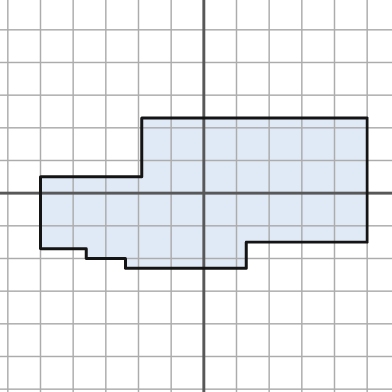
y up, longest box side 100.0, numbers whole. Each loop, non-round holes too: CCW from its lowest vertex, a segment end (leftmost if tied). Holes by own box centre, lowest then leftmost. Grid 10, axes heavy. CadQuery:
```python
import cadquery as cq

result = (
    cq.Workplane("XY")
    .moveTo(-24.0, -23.0)
    .lineTo(13.0, -23.0)
    .lineTo(13.0, -15.0)
    .lineTo(50.0, -15.0)
    .lineTo(50.0, 23.0)
    .lineTo(-19.0, 23.0)
    .lineTo(-19.0, 5.0)
    .lineTo(-50.0, 5.0)
    .lineTo(-50.0, -17.0)
    .lineTo(-36.0, -17.0)
    .lineTo(-36.0, -20.0)
    .lineTo(-24.0, -20.0)
    .close()
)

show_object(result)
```